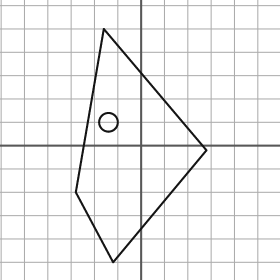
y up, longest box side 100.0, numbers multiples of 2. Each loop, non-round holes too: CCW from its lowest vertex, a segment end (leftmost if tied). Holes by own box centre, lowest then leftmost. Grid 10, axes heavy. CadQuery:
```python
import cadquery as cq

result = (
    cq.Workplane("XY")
    .moveTo(-12.0, -50.0)
    .lineTo(28.0, -2.0)
    .lineTo(-16.0, 50.0)
    .lineTo(-28.0, -20.0)
    .close()
    .moveTo(-14.0, 10.0)
    .circle(4.0)
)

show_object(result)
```